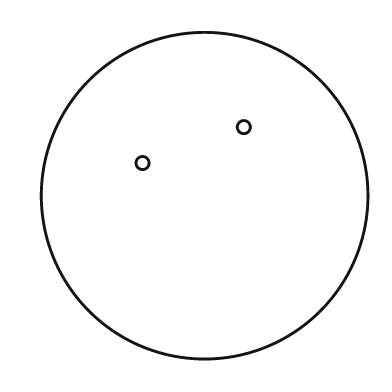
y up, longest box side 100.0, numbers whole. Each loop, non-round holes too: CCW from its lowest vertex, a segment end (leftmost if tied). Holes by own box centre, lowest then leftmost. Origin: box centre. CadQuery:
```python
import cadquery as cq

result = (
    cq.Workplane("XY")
    .moveTo(0.0, 0.0)
    .circle(50.0)
    .moveTo(-19.0, 10.0)
    .circle(2.0)
    .moveTo(12.0, 21.0)
    .circle(2.0)
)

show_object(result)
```